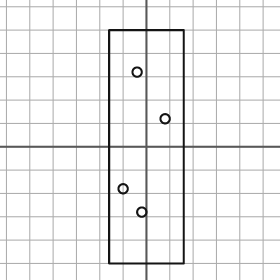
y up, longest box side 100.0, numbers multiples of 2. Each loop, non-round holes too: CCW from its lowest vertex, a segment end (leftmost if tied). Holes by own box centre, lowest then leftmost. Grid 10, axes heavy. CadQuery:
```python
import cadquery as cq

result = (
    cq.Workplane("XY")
    .moveTo(-16.0, -50.0)
    .lineTo(16.0, -50.0)
    .lineTo(16.0, 50.0)
    .lineTo(-16.0, 50.0)
    .close()
    .moveTo(-2.0, -28.0)
    .circle(2.0)
    .moveTo(-10.0, -18.0)
    .circle(2.0)
    .moveTo(8.0, 12.0)
    .circle(2.0)
    .moveTo(-4.0, 32.0)
    .circle(2.0)
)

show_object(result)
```